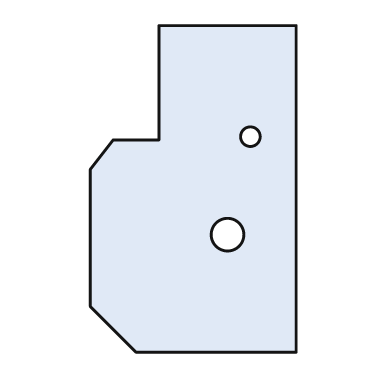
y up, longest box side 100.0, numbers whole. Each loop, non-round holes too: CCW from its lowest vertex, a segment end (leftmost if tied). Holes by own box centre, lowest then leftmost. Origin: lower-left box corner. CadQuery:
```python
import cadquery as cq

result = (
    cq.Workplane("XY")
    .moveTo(14.0, 0.0)
    .lineTo(63.0, 0.0)
    .lineTo(63.0, 100.0)
    .lineTo(21.0, 100.0)
    .lineTo(21.0, 65.0)
    .lineTo(7.0, 65.0)
    .lineTo(0.0, 56.0)
    .lineTo(0.0, 14.0)
    .close()
    .moveTo(42.0, 36.0)
    .circle(5.0)
    .moveTo(49.0, 66.0)
    .circle(3.0)
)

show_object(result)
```